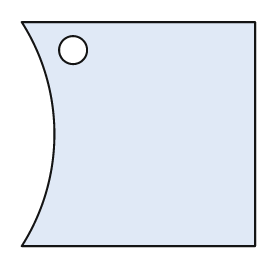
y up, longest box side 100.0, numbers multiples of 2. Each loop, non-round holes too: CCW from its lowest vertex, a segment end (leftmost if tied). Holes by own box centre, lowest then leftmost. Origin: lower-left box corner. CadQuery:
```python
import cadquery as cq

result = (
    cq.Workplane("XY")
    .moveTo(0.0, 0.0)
    .lineTo(100.0, 0.0)
    .lineTo(100.0, 96.0)
    .lineTo(0.0, 96.0)
    .threePointArc((14.0, 48.0), (0.0, 0.0))
    .close()
    .moveTo(22.0, 84.0)
    .circle(6.0)
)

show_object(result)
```